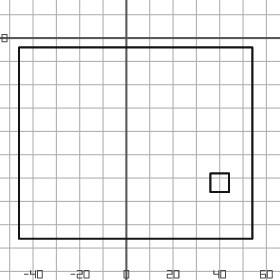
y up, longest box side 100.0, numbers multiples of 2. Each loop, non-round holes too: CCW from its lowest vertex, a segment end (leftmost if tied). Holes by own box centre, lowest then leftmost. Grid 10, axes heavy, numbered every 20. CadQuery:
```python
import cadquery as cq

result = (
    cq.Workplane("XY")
    .moveTo(-46.0, -86.0)
    .lineTo(54.0, -86.0)
    .lineTo(54.0, -4.0)
    .lineTo(-46.0, -4.0)
    .close()
    .moveTo(36.0, -66.0)
    .lineTo(44.0, -66.0)
    .lineTo(44.0, -58.0)
    .lineTo(36.0, -58.0)
    .close()
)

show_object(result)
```